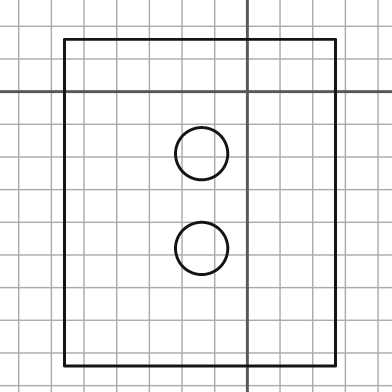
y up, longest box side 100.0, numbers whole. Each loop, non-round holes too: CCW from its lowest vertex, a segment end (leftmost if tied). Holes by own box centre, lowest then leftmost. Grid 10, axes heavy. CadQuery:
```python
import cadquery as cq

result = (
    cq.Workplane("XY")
    .moveTo(-56.0, -84.0)
    .lineTo(27.0, -84.0)
    .lineTo(27.0, 16.0)
    .lineTo(-56.0, 16.0)
    .close()
    .moveTo(-14.0, -48.0)
    .circle(8.0)
    .moveTo(-14.0, -19.0)
    .circle(8.0)
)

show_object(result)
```